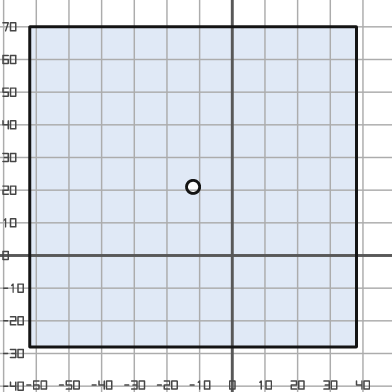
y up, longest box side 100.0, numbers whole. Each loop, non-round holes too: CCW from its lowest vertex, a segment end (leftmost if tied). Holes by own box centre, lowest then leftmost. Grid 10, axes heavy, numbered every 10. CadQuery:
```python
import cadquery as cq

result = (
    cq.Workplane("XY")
    .moveTo(-62.0, -28.0)
    .lineTo(38.0, -28.0)
    .lineTo(38.0, 70.0)
    .lineTo(-62.0, 70.0)
    .close()
    .moveTo(-12.0, 21.0)
    .circle(2.0)
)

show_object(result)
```